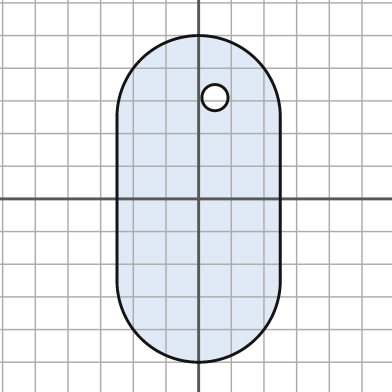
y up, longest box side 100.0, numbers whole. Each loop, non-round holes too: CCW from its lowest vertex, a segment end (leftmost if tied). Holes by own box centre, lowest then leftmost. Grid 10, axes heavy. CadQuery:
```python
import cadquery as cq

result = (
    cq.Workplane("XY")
    .moveTo(-25.0, -25.0)
    .threePointArc((0.0, -50.0), (25.0, -25.0))
    .lineTo(25.0, 25.0)
    .threePointArc((0.0, 50.0), (-25.0, 25.0))
    .close()
    .moveTo(5.0, 31.0)
    .circle(4.0)
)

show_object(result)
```